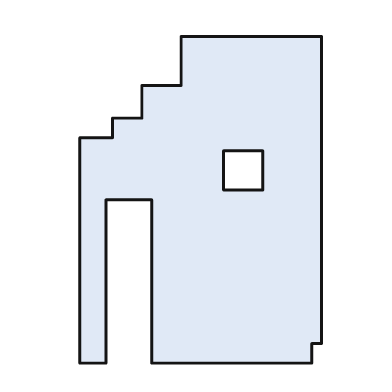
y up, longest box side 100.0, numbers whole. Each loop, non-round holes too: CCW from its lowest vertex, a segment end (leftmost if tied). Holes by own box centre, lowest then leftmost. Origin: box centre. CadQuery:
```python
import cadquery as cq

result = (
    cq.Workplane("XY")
    .moveTo(-37.0, -50.0)
    .lineTo(-29.0, -50.0)
    .lineTo(-29.0, 0.0)
    .lineTo(-15.0, 0.0)
    .lineTo(-15.0, -50.0)
    .lineTo(34.0, -50.0)
    .lineTo(34.0, -44.0)
    .lineTo(37.0, -44.0)
    .lineTo(37.0, 50.0)
    .lineTo(-6.0, 50.0)
    .lineTo(-6.0, 35.0)
    .lineTo(-18.0, 35.0)
    .lineTo(-18.0, 25.0)
    .lineTo(-27.0, 25.0)
    .lineTo(-27.0, 19.0)
    .lineTo(-37.0, 19.0)
    .close()
    .moveTo(7.0, 3.0)
    .lineTo(19.0, 3.0)
    .lineTo(19.0, 15.0)
    .lineTo(7.0, 15.0)
    .close()
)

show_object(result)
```